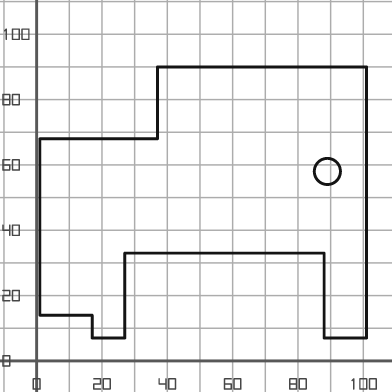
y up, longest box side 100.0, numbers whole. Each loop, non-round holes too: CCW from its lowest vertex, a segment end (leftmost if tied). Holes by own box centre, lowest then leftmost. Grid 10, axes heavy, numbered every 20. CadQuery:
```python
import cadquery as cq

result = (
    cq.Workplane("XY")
    .moveTo(17.0, 7.0)
    .lineTo(27.0, 7.0)
    .lineTo(27.0, 33.0)
    .lineTo(88.0, 33.0)
    .lineTo(88.0, 7.0)
    .lineTo(101.0, 7.0)
    .lineTo(101.0, 90.0)
    .lineTo(37.0, 90.0)
    .lineTo(37.0, 68.0)
    .lineTo(1.0, 68.0)
    .lineTo(1.0, 14.0)
    .lineTo(17.0, 14.0)
    .close()
    .moveTo(89.0, 58.0)
    .circle(4.0)
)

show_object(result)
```